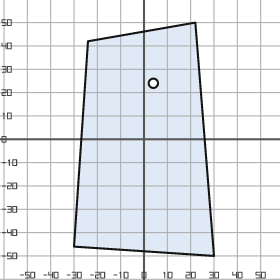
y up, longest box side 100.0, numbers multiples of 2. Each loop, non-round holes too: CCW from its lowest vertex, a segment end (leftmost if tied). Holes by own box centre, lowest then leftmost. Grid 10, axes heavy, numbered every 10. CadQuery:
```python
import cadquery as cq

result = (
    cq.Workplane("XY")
    .moveTo(30.0, -50.0)
    .lineTo(22.0, 50.0)
    .lineTo(-24.0, 42.0)
    .lineTo(-30.0, -46.0)
    .close()
    .moveTo(4.0, 24.0)
    .circle(2.0)
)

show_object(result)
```